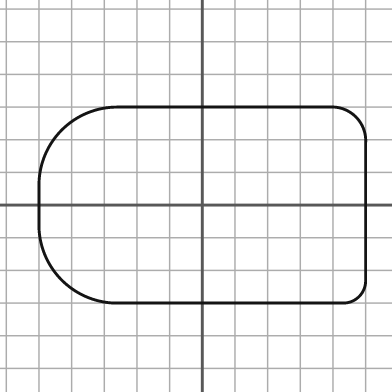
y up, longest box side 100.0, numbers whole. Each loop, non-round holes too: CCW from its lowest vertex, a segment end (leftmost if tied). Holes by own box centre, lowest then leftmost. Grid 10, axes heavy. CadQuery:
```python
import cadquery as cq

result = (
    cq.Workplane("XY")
    .moveTo(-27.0, -30.0)
    .lineTo(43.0, -30.0)
    .threePointArc((48.0, -28.0), (50.0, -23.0))
    .lineTo(50.0, 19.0)
    .threePointArc((47.0, 27.0), (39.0, 30.0))
    .lineTo(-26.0, 30.0)
    .threePointArc((-43.0, 23.0), (-50.0, 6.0))
    .lineTo(-50.0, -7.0)
    .threePointArc((-43.0, -23.0), (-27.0, -30.0))
    .close()
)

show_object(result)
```